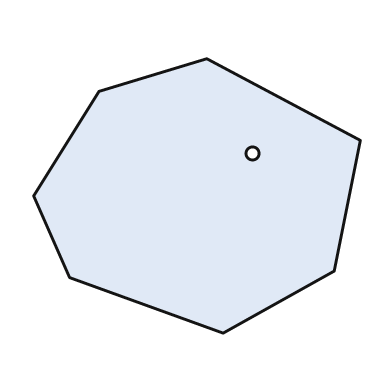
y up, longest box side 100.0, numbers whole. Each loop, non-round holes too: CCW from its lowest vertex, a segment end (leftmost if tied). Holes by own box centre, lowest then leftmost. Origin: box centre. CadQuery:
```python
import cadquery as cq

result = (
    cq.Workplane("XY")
    .moveTo(8.0, -42.0)
    .lineTo(42.0, -23.0)
    .lineTo(50.0, 17.0)
    .lineTo(3.0, 42.0)
    .lineTo(-30.0, 32.0)
    .lineTo(-50.0, 0.0)
    .lineTo(-39.0, -25.0)
    .close()
    .moveTo(17.0, 13.0)
    .circle(2.0)
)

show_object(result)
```